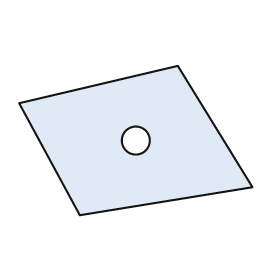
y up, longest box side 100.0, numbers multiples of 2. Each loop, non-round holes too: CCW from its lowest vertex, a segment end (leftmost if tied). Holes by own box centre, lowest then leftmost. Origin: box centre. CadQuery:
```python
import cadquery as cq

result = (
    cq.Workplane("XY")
    .moveTo(-24.0, -32.0)
    .lineTo(50.0, -20.0)
    .lineTo(18.0, 32.0)
    .lineTo(-50.0, 16.0)
    .close()
    .moveTo(0.0, 0.0)
    .circle(6.0)
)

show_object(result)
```